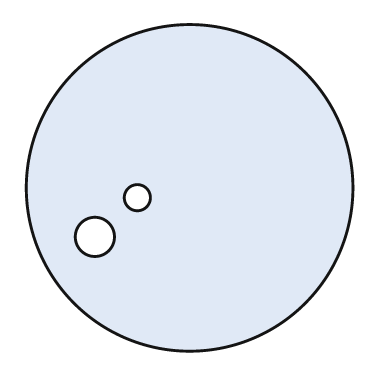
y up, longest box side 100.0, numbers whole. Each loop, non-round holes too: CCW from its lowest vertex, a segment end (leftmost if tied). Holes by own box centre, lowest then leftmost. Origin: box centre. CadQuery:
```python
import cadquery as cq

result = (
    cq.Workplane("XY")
    .moveTo(0.0, 0.0)
    .circle(50.0)
    .moveTo(-29.0, -15.0)
    .circle(6.0)
    .moveTo(-16.0, -3.0)
    .circle(4.0)
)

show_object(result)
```